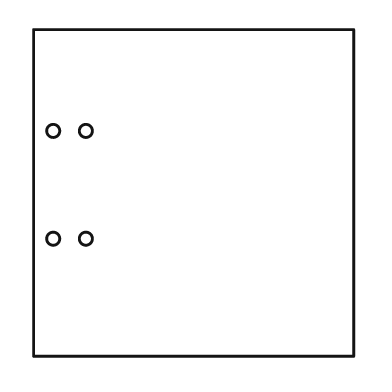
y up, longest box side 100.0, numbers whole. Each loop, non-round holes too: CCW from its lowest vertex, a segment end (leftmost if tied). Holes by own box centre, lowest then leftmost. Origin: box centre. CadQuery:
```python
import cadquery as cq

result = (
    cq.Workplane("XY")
    .moveTo(-49.0, -50.0)
    .lineTo(49.0, -50.0)
    .lineTo(49.0, 50.0)
    .lineTo(-49.0, 50.0)
    .close()
    .moveTo(-43.0, -14.0)
    .circle(2.0)
    .moveTo(-33.0, -14.0)
    .circle(2.0)
    .moveTo(-43.0, 19.0)
    .circle(2.0)
    .moveTo(-33.0, 19.0)
    .circle(2.0)
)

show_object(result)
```